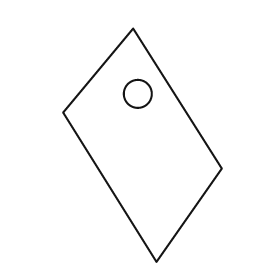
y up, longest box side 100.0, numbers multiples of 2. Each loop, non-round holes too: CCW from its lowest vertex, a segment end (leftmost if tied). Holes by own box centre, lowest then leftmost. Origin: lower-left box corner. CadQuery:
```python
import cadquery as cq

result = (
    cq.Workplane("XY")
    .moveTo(40.0, 0.0)
    .lineTo(68.0, 40.0)
    .lineTo(30.0, 100.0)
    .lineTo(0.0, 64.0)
    .close()
    .moveTo(32.0, 72.0)
    .circle(6.0)
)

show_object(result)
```